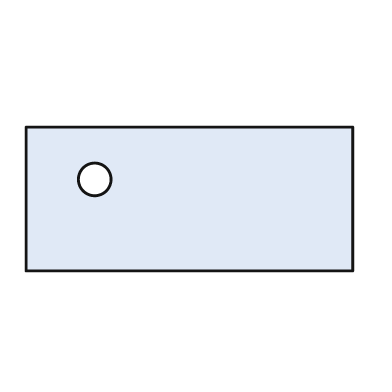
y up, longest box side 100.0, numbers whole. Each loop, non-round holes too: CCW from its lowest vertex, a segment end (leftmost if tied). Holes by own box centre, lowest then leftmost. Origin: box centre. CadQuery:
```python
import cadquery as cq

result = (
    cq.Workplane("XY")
    .moveTo(-50.0, -22.0)
    .lineTo(50.0, -22.0)
    .lineTo(50.0, 22.0)
    .lineTo(-50.0, 22.0)
    .close()
    .moveTo(-29.0, 6.0)
    .circle(5.0)
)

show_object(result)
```